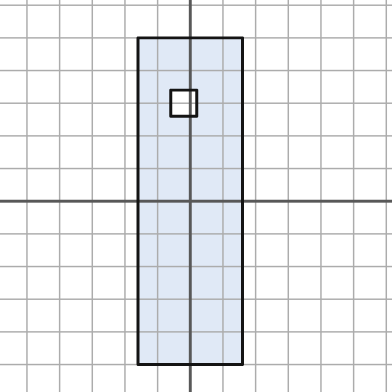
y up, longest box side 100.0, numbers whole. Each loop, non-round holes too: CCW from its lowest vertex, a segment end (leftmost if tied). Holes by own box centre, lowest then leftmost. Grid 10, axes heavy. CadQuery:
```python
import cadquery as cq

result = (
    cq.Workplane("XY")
    .moveTo(-16.0, -50.0)
    .lineTo(16.0, -50.0)
    .lineTo(16.0, 50.0)
    .lineTo(-16.0, 50.0)
    .close()
    .moveTo(-6.0, 26.0)
    .lineTo(2.0, 26.0)
    .lineTo(2.0, 34.0)
    .lineTo(-6.0, 34.0)
    .close()
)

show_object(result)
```